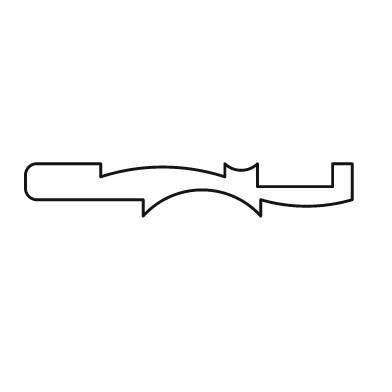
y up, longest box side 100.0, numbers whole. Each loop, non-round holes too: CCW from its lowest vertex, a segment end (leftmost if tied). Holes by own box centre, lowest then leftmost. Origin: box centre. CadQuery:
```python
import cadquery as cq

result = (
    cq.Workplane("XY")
    .moveTo(-14.0, -8.0)
    .threePointArc((4.0, 0.0), (22.0, -8.0))
    .lineTo(22.0, -3.0)
    .threePointArc((36.0, -5.0), (50.0, -3.0))
    .lineTo(50.0, 8.0)
    .lineTo(44.0, 8.0)
    .lineTo(44.0, 1.0)
    .lineTo(21.0, 1.0)
    .lineTo(21.0, 8.0)
    .threePointArc((16.0, 6.0), (11.0, 8.0))
    .lineTo(11.0, 4.0)
    .threePointArc((-8.0, 7.0), (-27.0, 4.0))
    .lineTo(-27.0, 8.0)
    .lineTo(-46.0, 8.0)
    .threePointArc((-49.0, 7.0), (-50.0, 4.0))
    .lineTo(-50.0, 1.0)
    .threePointArc((-49.0, -2.0), (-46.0, -3.0))
    .lineTo(-14.0, -3.0)
    .close()
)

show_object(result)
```